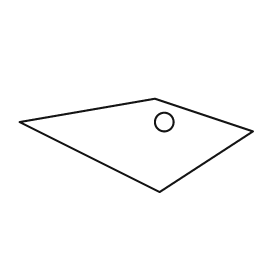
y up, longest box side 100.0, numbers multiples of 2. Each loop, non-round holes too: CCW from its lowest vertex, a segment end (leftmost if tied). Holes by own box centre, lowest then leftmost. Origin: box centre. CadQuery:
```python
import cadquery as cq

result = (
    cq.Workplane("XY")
    .moveTo(10.0, -20.0)
    .lineTo(50.0, 6.0)
    .lineTo(8.0, 20.0)
    .lineTo(-50.0, 10.0)
    .close()
    .moveTo(12.0, 10.0)
    .circle(4.0)
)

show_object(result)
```